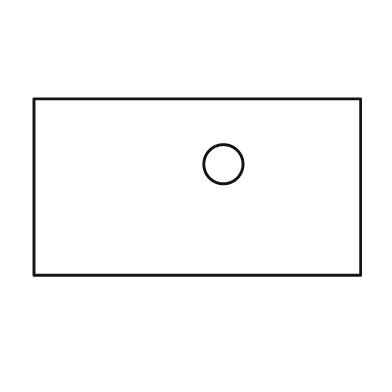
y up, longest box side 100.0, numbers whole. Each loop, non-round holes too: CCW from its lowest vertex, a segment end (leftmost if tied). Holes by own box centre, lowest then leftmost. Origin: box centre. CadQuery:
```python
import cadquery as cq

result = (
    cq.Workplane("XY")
    .moveTo(-50.0, -27.0)
    .lineTo(50.0, -27.0)
    .lineTo(50.0, 27.0)
    .lineTo(-50.0, 27.0)
    .close()
    .moveTo(8.0, 7.0)
    .circle(6.0)
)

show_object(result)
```